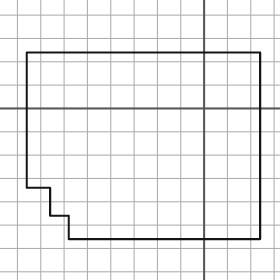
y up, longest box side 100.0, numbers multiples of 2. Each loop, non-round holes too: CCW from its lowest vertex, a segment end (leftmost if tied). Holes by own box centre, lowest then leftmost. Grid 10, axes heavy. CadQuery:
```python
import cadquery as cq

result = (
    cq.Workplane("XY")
    .moveTo(-58.0, -56.0)
    .lineTo(24.0, -56.0)
    .lineTo(24.0, 24.0)
    .lineTo(-76.0, 24.0)
    .lineTo(-76.0, -34.0)
    .lineTo(-66.0, -34.0)
    .lineTo(-66.0, -46.0)
    .lineTo(-58.0, -46.0)
    .close()
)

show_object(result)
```